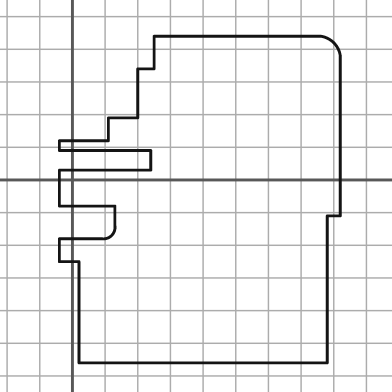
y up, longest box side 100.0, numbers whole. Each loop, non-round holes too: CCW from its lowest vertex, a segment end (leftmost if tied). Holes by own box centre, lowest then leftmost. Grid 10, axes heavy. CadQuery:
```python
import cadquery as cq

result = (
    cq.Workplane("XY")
    .moveTo(2.0, -56.0)
    .lineTo(78.0, -56.0)
    .lineTo(78.0, -11.0)
    .lineTo(82.0, -11.0)
    .lineTo(82.0, 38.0)
    .threePointArc((80.0, 42.0), (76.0, 44.0))
    .lineTo(25.0, 44.0)
    .lineTo(25.0, 34.0)
    .lineTo(20.0, 34.0)
    .lineTo(20.0, 19.0)
    .lineTo(11.0, 19.0)
    .lineTo(11.0, 12.0)
    .lineTo(-4.0, 12.0)
    .lineTo(-4.0, 9.0)
    .lineTo(24.0, 9.0)
    .lineTo(24.0, 3.0)
    .lineTo(-4.0, 3.0)
    .lineTo(-4.0, -8.0)
    .lineTo(13.0, -8.0)
    .lineTo(13.0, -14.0)
    .threePointArc((12.0, -17.0), (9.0, -18.0))
    .lineTo(-4.0, -18.0)
    .lineTo(-4.0, -25.0)
    .lineTo(2.0, -25.0)
    .close()
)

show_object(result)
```